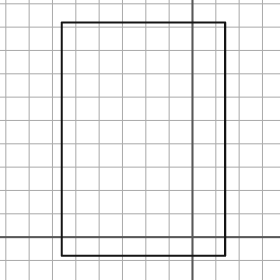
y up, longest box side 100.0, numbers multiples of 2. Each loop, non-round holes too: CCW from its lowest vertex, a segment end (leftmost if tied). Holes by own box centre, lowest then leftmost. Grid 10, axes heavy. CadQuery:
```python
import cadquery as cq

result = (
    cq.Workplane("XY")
    .moveTo(-56.0, -8.0)
    .lineTo(14.0, -8.0)
    .lineTo(14.0, 92.0)
    .lineTo(-56.0, 92.0)
    .close()
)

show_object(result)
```